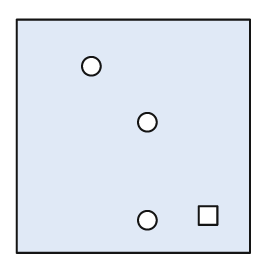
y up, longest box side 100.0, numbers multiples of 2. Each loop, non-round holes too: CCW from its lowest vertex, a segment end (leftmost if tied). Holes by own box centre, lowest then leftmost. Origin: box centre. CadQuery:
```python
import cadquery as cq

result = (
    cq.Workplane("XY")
    .moveTo(-50.0, -50.0)
    .lineTo(50.0, -50.0)
    .lineTo(50.0, 50.0)
    .lineTo(-50.0, 50.0)
    .close()
    .moveTo(6.0, -36.0)
    .circle(4.0)
    .moveTo(28.0, -38.0)
    .lineTo(36.0, -38.0)
    .lineTo(36.0, -30.0)
    .lineTo(28.0, -30.0)
    .close()
    .moveTo(6.0, 6.0)
    .circle(4.0)
    .moveTo(-18.0, 30.0)
    .circle(4.0)
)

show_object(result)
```